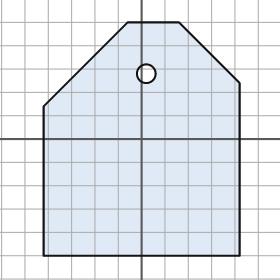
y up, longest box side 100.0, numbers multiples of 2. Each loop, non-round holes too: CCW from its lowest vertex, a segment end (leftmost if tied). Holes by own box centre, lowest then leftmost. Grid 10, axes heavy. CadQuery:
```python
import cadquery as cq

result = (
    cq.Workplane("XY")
    .moveTo(-42.0, -50.0)
    .lineTo(42.0, -50.0)
    .lineTo(42.0, 24.0)
    .lineTo(16.0, 50.0)
    .lineTo(-6.0, 50.0)
    .lineTo(-42.0, 14.0)
    .close()
    .moveTo(2.0, 28.0)
    .circle(4.0)
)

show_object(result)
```